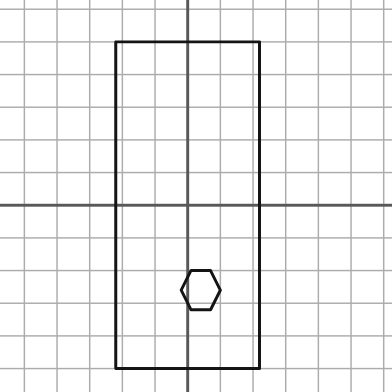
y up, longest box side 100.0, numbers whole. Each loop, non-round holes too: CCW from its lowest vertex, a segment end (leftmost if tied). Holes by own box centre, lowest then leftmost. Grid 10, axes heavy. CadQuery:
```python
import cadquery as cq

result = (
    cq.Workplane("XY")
    .moveTo(-22.0, -50.0)
    .lineTo(22.0, -50.0)
    .lineTo(22.0, 50.0)
    .lineTo(-22.0, 50.0)
    .close()
    .moveTo(1.0, -32.0)
    .lineTo(7.0, -32.0)
    .lineTo(10.0, -26.0)
    .lineTo(7.0, -20.0)
    .lineTo(1.0, -20.0)
    .lineTo(-2.0, -26.0)
    .close()
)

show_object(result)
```